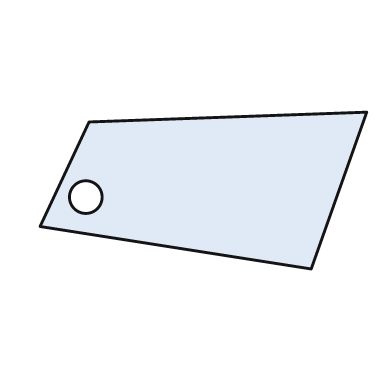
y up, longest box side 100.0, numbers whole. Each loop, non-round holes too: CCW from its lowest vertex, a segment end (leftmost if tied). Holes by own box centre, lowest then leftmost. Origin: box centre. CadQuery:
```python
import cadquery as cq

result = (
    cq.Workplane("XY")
    .moveTo(33.0, -24.0)
    .lineTo(50.0, 24.0)
    .lineTo(-35.0, 21.0)
    .lineTo(-50.0, -11.0)
    .close()
    .moveTo(-36.0, -2.0)
    .circle(5.0)
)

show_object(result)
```